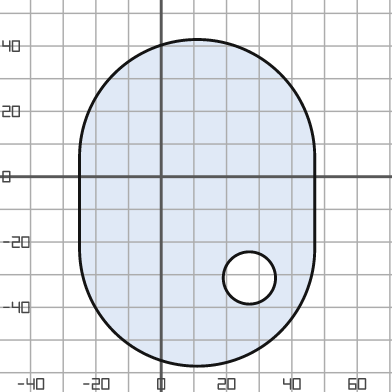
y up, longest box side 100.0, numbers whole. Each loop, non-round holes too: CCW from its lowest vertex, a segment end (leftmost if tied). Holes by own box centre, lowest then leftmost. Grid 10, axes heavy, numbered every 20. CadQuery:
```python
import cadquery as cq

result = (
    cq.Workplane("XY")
    .moveTo(-25.0, -22.0)
    .threePointArc((11.0, -58.0), (47.0, -22.0))
    .lineTo(47.0, 6.0)
    .threePointArc((11.0, 42.0), (-25.0, 6.0))
    .close()
    .moveTo(27.0, -31.0)
    .circle(8.0)
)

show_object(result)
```